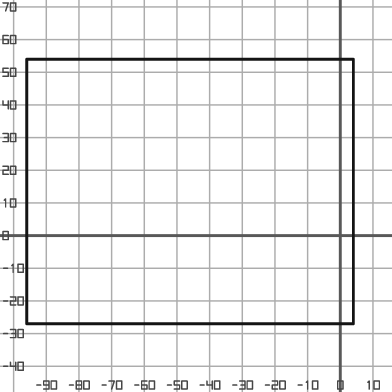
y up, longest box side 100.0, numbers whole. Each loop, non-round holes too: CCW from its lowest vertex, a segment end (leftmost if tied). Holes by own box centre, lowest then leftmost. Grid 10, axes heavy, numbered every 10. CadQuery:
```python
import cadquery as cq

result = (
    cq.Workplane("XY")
    .moveTo(-96.0, -27.0)
    .lineTo(4.0, -27.0)
    .lineTo(4.0, 54.0)
    .lineTo(-96.0, 54.0)
    .close()
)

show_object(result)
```